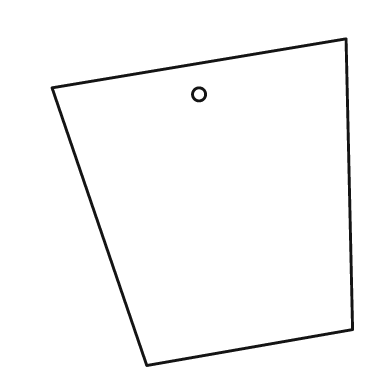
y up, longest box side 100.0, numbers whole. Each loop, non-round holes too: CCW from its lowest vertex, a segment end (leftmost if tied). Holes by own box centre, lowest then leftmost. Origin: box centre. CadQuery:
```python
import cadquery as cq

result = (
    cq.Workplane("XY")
    .moveTo(-17.0, -50.0)
    .lineTo(46.0, -39.0)
    .lineTo(44.0, 50.0)
    .lineTo(-46.0, 35.0)
    .close()
    .moveTo(-1.0, 33.0)
    .circle(2.0)
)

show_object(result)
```